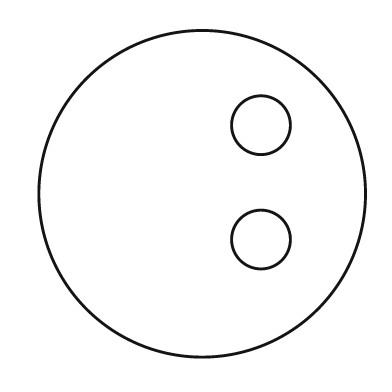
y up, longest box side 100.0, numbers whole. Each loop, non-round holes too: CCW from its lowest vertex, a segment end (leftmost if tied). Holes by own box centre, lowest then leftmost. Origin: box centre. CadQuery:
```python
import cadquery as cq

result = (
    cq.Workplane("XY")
    .moveTo(0.0, 0.0)
    .circle(50.0)
    .moveTo(18.0, -14.0)
    .circle(9.0)
    .moveTo(18.0, 21.0)
    .circle(9.0)
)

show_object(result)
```